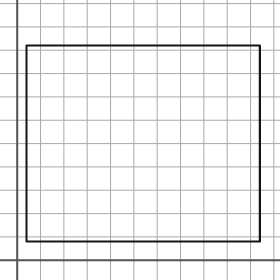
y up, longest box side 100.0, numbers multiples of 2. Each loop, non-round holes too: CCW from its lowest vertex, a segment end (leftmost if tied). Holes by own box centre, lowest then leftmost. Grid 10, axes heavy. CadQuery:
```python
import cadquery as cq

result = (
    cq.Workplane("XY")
    .moveTo(4.0, 8.0)
    .lineTo(104.0, 8.0)
    .lineTo(104.0, 92.0)
    .lineTo(4.0, 92.0)
    .close()
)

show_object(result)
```